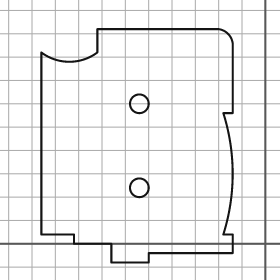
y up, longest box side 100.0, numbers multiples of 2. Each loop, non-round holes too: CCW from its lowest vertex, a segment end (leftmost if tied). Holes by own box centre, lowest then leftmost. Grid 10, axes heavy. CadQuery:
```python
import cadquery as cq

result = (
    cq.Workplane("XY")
    .moveTo(-66.0, -8.0)
    .lineTo(-50.0, -8.0)
    .lineTo(-50.0, -4.0)
    .lineTo(-14.0, -4.0)
    .lineTo(-14.0, 4.0)
    .lineTo(-18.0, 4.0)
    .threePointArc((-14.0, 30.0), (-18.0, 56.0))
    .lineTo(-14.0, 56.0)
    .lineTo(-14.0, 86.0)
    .threePointArc((-16.0, 90.0), (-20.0, 92.0))
    .lineTo(-72.0, 92.0)
    .lineTo(-72.0, 82.0)
    .threePointArc((-84.0, 78.0), (-96.0, 82.0))
    .lineTo(-96.0, 4.0)
    .lineTo(-82.0, 4.0)
    .lineTo(-82.0, 0.0)
    .lineTo(-66.0, 0.0)
    .close()
    .moveTo(-54.0, 24.0)
    .circle(4.0)
    .moveTo(-54.0, 60.0)
    .circle(4.0)
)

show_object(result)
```